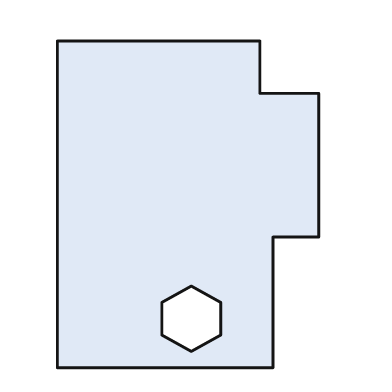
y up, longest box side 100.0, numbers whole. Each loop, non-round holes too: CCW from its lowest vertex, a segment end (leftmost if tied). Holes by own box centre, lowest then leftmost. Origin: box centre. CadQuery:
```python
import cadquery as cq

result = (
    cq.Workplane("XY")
    .moveTo(-40.0, -50.0)
    .lineTo(26.0, -50.0)
    .lineTo(26.0, -10.0)
    .lineTo(40.0, -10.0)
    .lineTo(40.0, 34.0)
    .lineTo(22.0, 34.0)
    .lineTo(22.0, 50.0)
    .lineTo(-40.0, 50.0)
    .close()
    .moveTo(1.0, -45.0)
    .lineTo(10.0, -40.0)
    .lineTo(10.0, -30.0)
    .lineTo(1.0, -25.0)
    .lineTo(-8.0, -30.0)
    .lineTo(-8.0, -40.0)
    .close()
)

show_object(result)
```